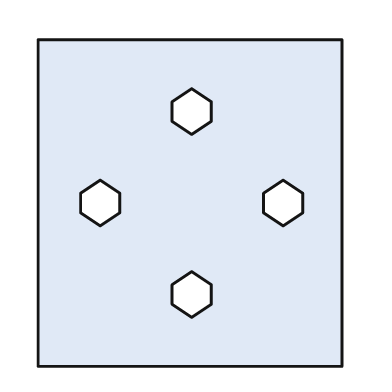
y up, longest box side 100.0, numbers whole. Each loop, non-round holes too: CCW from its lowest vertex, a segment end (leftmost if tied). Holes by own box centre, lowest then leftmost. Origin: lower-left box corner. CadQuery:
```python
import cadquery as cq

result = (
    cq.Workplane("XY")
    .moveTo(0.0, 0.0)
    .lineTo(93.0, 0.0)
    .lineTo(93.0, 100.0)
    .lineTo(0.0, 100.0)
    .close()
    .moveTo(47.0, 15.0)
    .lineTo(53.0, 19.0)
    .lineTo(53.0, 25.0)
    .lineTo(47.0, 29.0)
    .lineTo(41.0, 25.0)
    .lineTo(41.0, 19.0)
    .close()
    .moveTo(19.0, 43.0)
    .lineTo(25.0, 47.0)
    .lineTo(25.0, 53.0)
    .lineTo(19.0, 57.0)
    .lineTo(13.0, 53.0)
    .lineTo(13.0, 47.0)
    .close()
    .moveTo(75.0, 43.0)
    .lineTo(81.0, 47.0)
    .lineTo(81.0, 53.0)
    .lineTo(75.0, 57.0)
    .lineTo(69.0, 53.0)
    .lineTo(69.0, 47.0)
    .close()
    .moveTo(47.0, 71.0)
    .lineTo(53.0, 75.0)
    .lineTo(53.0, 81.0)
    .lineTo(47.0, 85.0)
    .lineTo(41.0, 81.0)
    .lineTo(41.0, 75.0)
    .close()
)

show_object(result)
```